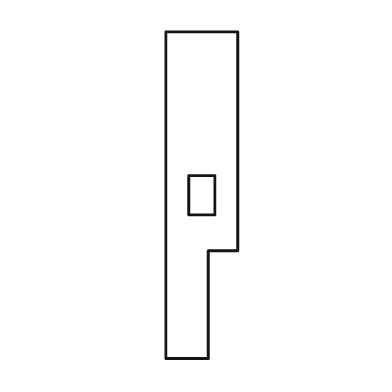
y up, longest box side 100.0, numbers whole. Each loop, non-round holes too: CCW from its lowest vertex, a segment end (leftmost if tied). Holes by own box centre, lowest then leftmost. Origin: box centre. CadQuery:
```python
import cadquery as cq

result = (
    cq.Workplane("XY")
    .moveTo(-11.0, -50.0)
    .lineTo(2.0, -50.0)
    .lineTo(2.0, -17.0)
    .lineTo(11.0, -17.0)
    .lineTo(11.0, 50.0)
    .lineTo(-11.0, 50.0)
    .close()
    .moveTo(-4.0, -6.0)
    .lineTo(4.0, -6.0)
    .lineTo(4.0, 6.0)
    .lineTo(-4.0, 6.0)
    .close()
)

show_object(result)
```